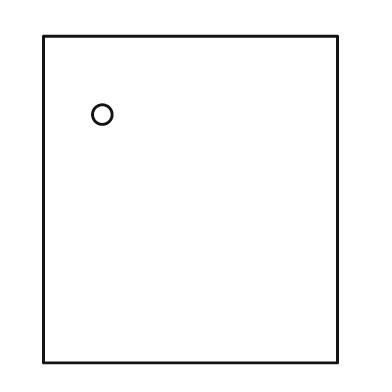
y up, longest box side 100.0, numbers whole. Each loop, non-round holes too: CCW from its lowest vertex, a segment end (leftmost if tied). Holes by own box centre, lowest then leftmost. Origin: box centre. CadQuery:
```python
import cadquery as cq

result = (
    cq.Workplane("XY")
    .moveTo(-45.0, -50.0)
    .lineTo(45.0, -50.0)
    .lineTo(45.0, 50.0)
    .lineTo(-45.0, 50.0)
    .close()
    .moveTo(-27.0, 26.0)
    .circle(3.0)
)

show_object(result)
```